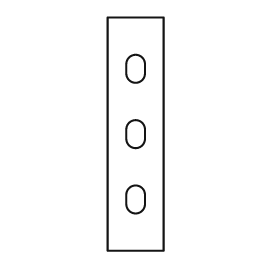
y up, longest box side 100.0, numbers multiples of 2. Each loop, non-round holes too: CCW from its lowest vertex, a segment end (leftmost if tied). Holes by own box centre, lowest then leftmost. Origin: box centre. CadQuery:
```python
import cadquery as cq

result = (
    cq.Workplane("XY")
    .moveTo(-12.0, -50.0)
    .lineTo(12.0, -50.0)
    .lineTo(12.0, 50.0)
    .lineTo(-12.0, 50.0)
    .close()
    .moveTo(-4.0, -30.0)
    .threePointArc((0.0, -34.0), (4.0, -30.0))
    .lineTo(4.0, -26.0)
    .threePointArc((0.0, -22.0), (-4.0, -26.0))
    .close()
    .moveTo(-4.0, -2.0)
    .threePointArc((0.0, -6.0), (4.0, -2.0))
    .lineTo(4.0, 2.0)
    .threePointArc((0.0, 6.0), (-4.0, 2.0))
    .close()
    .moveTo(-4.0, 26.0)
    .threePointArc((0.0, 22.0), (4.0, 26.0))
    .lineTo(4.0, 30.0)
    .threePointArc((0.0, 34.0), (-4.0, 30.0))
    .close()
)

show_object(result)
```